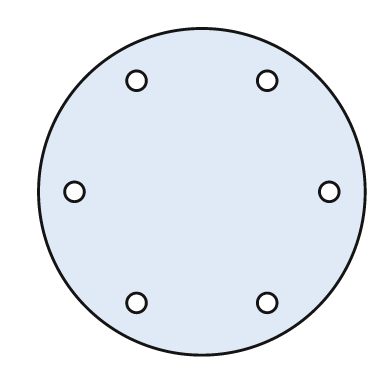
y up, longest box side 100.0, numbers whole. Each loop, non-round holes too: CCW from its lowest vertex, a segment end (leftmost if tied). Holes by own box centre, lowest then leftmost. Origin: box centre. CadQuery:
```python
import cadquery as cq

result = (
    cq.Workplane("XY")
    .moveTo(0.0, 0.0)
    .circle(50.0)
    .moveTo(-20.0, -34.0)
    .circle(3.0)
    .moveTo(20.0, -34.0)
    .circle(3.0)
    .moveTo(-39.0, 0.0)
    .circle(3.0)
    .moveTo(39.0, 0.0)
    .circle(3.0)
    .moveTo(-20.0, 34.0)
    .circle(3.0)
    .moveTo(20.0, 34.0)
    .circle(3.0)
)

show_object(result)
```